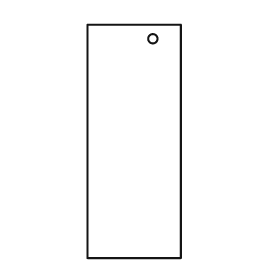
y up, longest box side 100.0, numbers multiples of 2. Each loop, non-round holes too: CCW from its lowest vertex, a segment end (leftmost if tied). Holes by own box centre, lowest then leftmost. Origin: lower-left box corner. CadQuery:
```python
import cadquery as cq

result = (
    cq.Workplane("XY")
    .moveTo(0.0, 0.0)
    .lineTo(40.0, 0.0)
    .lineTo(40.0, 100.0)
    .lineTo(0.0, 100.0)
    .close()
    .moveTo(28.0, 94.0)
    .circle(2.0)
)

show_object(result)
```